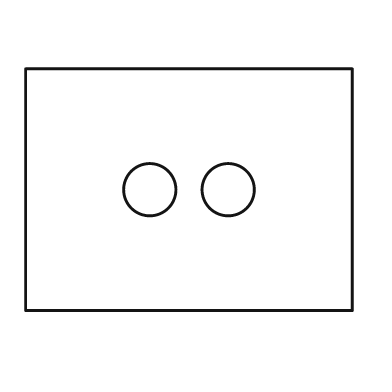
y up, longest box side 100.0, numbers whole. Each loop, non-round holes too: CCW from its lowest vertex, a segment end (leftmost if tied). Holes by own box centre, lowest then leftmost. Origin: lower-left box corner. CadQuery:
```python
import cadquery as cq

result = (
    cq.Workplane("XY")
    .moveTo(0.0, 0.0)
    .lineTo(100.0, 0.0)
    .lineTo(100.0, 74.0)
    .lineTo(0.0, 74.0)
    .close()
    .moveTo(38.0, 37.0)
    .circle(8.0)
    .moveTo(62.0, 37.0)
    .circle(8.0)
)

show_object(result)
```